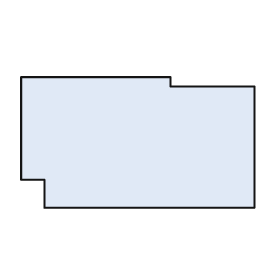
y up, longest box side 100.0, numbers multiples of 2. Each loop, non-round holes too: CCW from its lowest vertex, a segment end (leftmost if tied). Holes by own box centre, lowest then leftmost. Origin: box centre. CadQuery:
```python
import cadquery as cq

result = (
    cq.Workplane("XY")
    .moveTo(-40.0, -28.0)
    .lineTo(50.0, -28.0)
    .lineTo(50.0, 24.0)
    .lineTo(14.0, 24.0)
    .lineTo(14.0, 28.0)
    .lineTo(-50.0, 28.0)
    .lineTo(-50.0, -16.0)
    .lineTo(-40.0, -16.0)
    .close()
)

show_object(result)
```